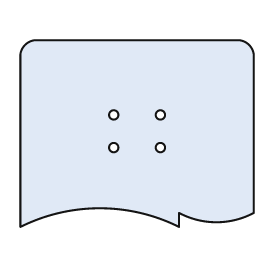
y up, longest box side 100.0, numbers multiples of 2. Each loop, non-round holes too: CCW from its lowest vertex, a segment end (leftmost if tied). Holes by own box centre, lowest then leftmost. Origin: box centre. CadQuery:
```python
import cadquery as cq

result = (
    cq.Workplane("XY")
    .moveTo(-50.0, -40.0)
    .threePointArc((-16.0, -32.0), (18.0, -40.0))
    .lineTo(18.0, -34.0)
    .threePointArc((34.0, -38.0), (50.0, -34.0))
    .lineTo(50.0, 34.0)
    .threePointArc((48.0, 38.0), (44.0, 40.0))
    .lineTo(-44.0, 40.0)
    .threePointArc((-48.0, 38.0), (-50.0, 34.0))
    .close()
    .moveTo(-10.0, -6.0)
    .circle(2.0)
    .moveTo(10.0, -6.0)
    .circle(2.0)
    .moveTo(-10.0, 8.0)
    .circle(2.0)
    .moveTo(10.0, 8.0)
    .circle(2.0)
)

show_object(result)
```